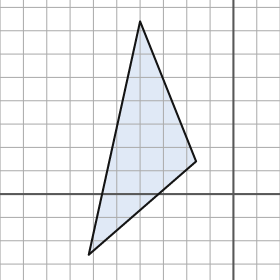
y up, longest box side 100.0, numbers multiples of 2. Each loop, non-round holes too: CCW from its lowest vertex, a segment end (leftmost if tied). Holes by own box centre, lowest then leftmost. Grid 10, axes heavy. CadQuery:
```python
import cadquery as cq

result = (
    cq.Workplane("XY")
    .moveTo(-62.0, -26.0)
    .lineTo(-16.0, 14.0)
    .lineTo(-40.0, 74.0)
    .close()
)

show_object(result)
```